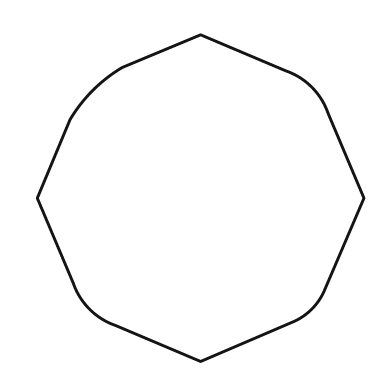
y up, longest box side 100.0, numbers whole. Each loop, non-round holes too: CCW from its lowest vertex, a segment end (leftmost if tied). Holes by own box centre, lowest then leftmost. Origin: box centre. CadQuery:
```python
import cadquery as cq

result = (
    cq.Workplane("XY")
    .moveTo(0.0, -50.0)
    .lineTo(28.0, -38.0)
    .threePointArc((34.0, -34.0), (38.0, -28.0))
    .lineTo(50.0, 0.0)
    .lineTo(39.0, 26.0)
    .threePointArc((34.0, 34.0), (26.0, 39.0))
    .lineTo(0.0, 50.0)
    .lineTo(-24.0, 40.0)
    .threePointArc((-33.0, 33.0), (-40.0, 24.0))
    .lineTo(-50.0, 0.0)
    .lineTo(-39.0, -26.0)
    .threePointArc((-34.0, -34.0), (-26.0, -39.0))
    .close()
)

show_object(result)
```